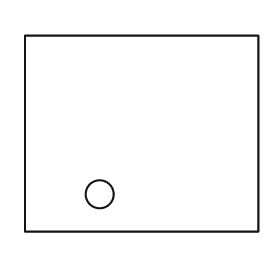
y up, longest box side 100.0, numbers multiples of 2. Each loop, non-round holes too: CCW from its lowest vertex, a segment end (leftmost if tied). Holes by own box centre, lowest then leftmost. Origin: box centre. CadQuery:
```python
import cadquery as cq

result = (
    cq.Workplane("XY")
    .moveTo(-50.0, -42.0)
    .lineTo(50.0, -42.0)
    .lineTo(50.0, 42.0)
    .lineTo(-50.0, 42.0)
    .close()
    .moveTo(-18.0, -26.0)
    .circle(6.0)
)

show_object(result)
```